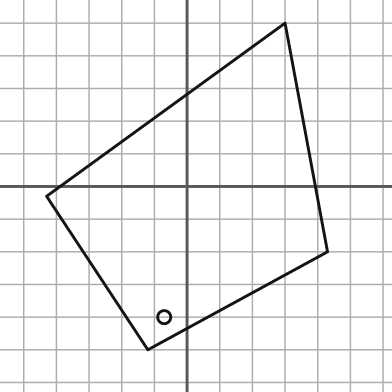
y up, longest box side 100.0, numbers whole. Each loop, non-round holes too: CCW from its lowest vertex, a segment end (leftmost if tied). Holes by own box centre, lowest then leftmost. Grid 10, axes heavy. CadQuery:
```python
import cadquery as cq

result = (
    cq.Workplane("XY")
    .moveTo(-12.0, -50.0)
    .lineTo(43.0, -20.0)
    .lineTo(30.0, 50.0)
    .lineTo(-43.0, -3.0)
    .close()
    .moveTo(-7.0, -40.0)
    .circle(2.0)
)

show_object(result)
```